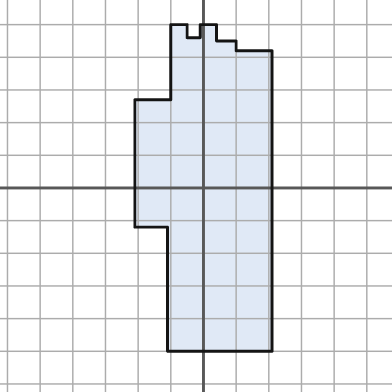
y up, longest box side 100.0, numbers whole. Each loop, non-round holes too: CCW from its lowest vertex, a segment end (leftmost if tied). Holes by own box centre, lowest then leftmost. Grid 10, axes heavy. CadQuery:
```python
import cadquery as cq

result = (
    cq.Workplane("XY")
    .moveTo(-11.0, -50.0)
    .lineTo(21.0, -50.0)
    .lineTo(21.0, 42.0)
    .lineTo(10.0, 42.0)
    .lineTo(10.0, 45.0)
    .lineTo(4.0, 45.0)
    .lineTo(4.0, 50.0)
    .lineTo(-1.0, 50.0)
    .lineTo(-1.0, 46.0)
    .lineTo(-5.0, 46.0)
    .lineTo(-5.0, 50.0)
    .lineTo(-10.0, 50.0)
    .lineTo(-10.0, 27.0)
    .lineTo(-21.0, 27.0)
    .lineTo(-21.0, -12.0)
    .lineTo(-11.0, -12.0)
    .close()
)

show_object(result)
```